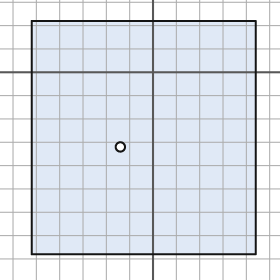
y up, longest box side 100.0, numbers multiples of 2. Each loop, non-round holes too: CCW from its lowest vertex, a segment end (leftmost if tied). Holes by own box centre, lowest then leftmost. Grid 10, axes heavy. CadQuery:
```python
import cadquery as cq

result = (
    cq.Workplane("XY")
    .moveTo(-52.0, -78.0)
    .lineTo(44.0, -78.0)
    .lineTo(44.0, 22.0)
    .lineTo(-52.0, 22.0)
    .close()
    .moveTo(-14.0, -32.0)
    .circle(2.0)
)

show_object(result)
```